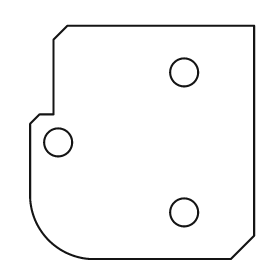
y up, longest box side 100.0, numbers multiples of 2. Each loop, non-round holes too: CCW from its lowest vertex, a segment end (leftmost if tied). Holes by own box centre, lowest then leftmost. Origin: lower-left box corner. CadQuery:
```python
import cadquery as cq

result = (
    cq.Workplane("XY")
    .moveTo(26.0, 0.0)
    .lineTo(86.0, 0.0)
    .lineTo(96.0, 10.0)
    .lineTo(96.0, 100.0)
    .lineTo(16.0, 100.0)
    .lineTo(10.0, 94.0)
    .lineTo(10.0, 62.0)
    .lineTo(4.0, 62.0)
    .lineTo(0.0, 58.0)
    .lineTo(0.0, 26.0)
    .threePointArc((8.0, 8.0), (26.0, 0.0))
    .close()
    .moveTo(66.0, 20.0)
    .circle(6.0)
    .moveTo(12.0, 50.0)
    .circle(6.0)
    .moveTo(66.0, 80.0)
    .circle(6.0)
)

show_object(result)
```